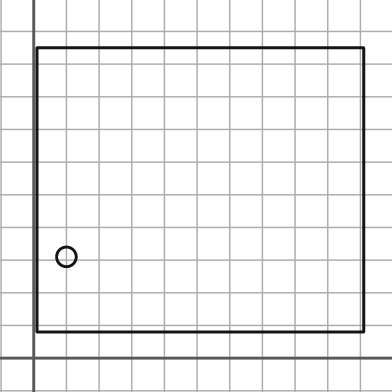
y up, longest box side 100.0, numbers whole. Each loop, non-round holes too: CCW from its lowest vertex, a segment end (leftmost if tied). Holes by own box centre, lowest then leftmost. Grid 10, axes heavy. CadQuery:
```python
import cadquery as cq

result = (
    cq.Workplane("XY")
    .moveTo(1.0, 8.0)
    .lineTo(101.0, 8.0)
    .lineTo(101.0, 95.0)
    .lineTo(1.0, 95.0)
    .close()
    .moveTo(10.0, 31.0)
    .circle(3.0)
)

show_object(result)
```